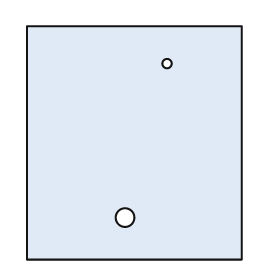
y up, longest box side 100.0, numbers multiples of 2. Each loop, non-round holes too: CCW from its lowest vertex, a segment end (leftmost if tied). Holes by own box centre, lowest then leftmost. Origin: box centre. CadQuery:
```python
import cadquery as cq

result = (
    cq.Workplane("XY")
    .moveTo(-46.0, -50.0)
    .lineTo(46.0, -50.0)
    .lineTo(46.0, 50.0)
    .lineTo(-46.0, 50.0)
    .close()
    .moveTo(-4.0, -32.0)
    .circle(4.0)
    .moveTo(14.0, 34.0)
    .circle(2.0)
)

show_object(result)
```